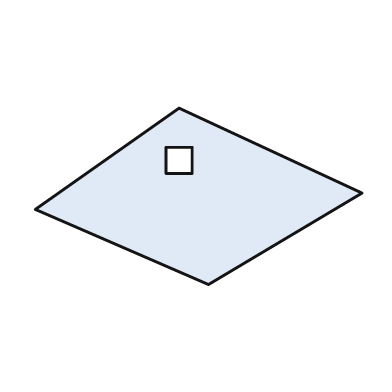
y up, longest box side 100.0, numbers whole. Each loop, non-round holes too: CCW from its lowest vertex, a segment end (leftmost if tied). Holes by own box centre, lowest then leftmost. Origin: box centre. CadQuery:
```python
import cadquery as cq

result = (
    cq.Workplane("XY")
    .moveTo(3.0, -27.0)
    .lineTo(50.0, 1.0)
    .lineTo(-6.0, 27.0)
    .lineTo(-50.0, -4.0)
    .close()
    .moveTo(-10.0, 7.0)
    .lineTo(-2.0, 7.0)
    .lineTo(-2.0, 15.0)
    .lineTo(-10.0, 15.0)
    .close()
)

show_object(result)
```